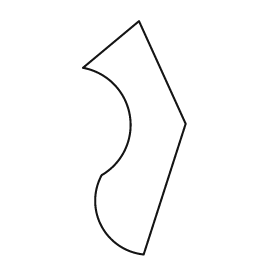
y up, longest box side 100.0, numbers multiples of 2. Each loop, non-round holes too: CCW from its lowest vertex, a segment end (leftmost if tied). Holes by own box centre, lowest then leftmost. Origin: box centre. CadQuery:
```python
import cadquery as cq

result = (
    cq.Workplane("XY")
    .moveTo(4.0, -50.0)
    .lineTo(22.0, 6.0)
    .lineTo(2.0, 50.0)
    .lineTo(-22.0, 30.0)
    .threePointArc((-2.0, 10.0), (-14.0, -16.0))
    .threePointArc((-14.0, -38.0), (4.0, -50.0))
    .close()
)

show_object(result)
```